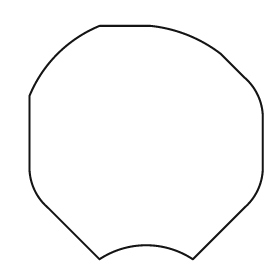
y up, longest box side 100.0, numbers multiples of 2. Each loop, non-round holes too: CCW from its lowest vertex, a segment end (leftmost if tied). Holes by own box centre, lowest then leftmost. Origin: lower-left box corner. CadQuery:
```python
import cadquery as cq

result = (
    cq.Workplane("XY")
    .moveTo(30.0, 0.0)
    .threePointArc((50.0, 6.0), (70.0, 0.0))
    .lineTo(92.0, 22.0)
    .threePointArc((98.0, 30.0), (100.0, 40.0))
    .lineTo(100.0, 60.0)
    .threePointArc((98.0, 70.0), (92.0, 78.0))
    .lineTo(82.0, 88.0)
    .threePointArc((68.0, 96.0), (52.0, 100.0))
    .lineTo(30.0, 100.0)
    .threePointArc((12.0, 88.0), (0.0, 70.0))
    .lineTo(0.0, 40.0)
    .threePointArc((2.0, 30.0), (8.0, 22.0))
    .close()
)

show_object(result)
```